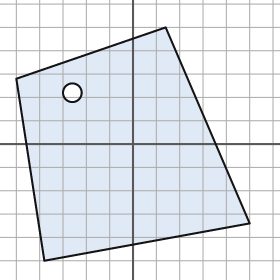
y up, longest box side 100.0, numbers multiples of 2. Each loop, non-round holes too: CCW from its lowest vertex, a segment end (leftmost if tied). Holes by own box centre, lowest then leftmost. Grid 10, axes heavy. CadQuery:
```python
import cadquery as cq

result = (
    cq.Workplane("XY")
    .moveTo(-38.0, -50.0)
    .lineTo(50.0, -34.0)
    .lineTo(14.0, 50.0)
    .lineTo(-50.0, 28.0)
    .close()
    .moveTo(-26.0, 22.0)
    .circle(4.0)
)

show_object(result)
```